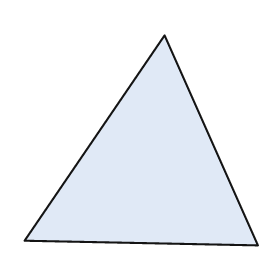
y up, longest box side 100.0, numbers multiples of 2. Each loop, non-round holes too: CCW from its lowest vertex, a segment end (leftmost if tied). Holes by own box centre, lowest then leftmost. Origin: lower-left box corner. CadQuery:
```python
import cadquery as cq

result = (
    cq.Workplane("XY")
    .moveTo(100.0, 0.0)
    .lineTo(60.0, 90.0)
    .lineTo(0.0, 2.0)
    .close()
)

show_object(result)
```